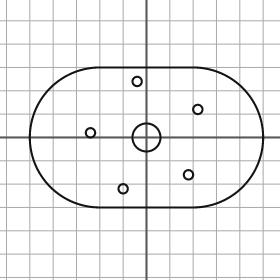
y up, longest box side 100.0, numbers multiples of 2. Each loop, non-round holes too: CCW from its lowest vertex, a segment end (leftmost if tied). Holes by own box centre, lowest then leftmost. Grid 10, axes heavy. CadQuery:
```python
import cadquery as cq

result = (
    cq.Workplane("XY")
    .moveTo(-20.0, -30.0)
    .lineTo(20.0, -30.0)
    .threePointArc((50.0, 0.0), (20.0, 30.0))
    .lineTo(-20.0, 30.0)
    .threePointArc((-50.0, 0.0), (-20.0, -30.0))
    .close()
    .moveTo(-10.0, -22.0)
    .circle(2.0)
    .moveTo(18.0, -16.0)
    .circle(2.0)
    .moveTo(0.0, 0.0)
    .circle(6.0)
    .moveTo(-24.0, 2.0)
    .circle(2.0)
    .moveTo(22.0, 12.0)
    .circle(2.0)
    .moveTo(-4.0, 24.0)
    .circle(2.0)
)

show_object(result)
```